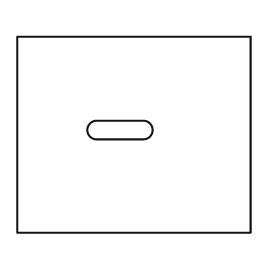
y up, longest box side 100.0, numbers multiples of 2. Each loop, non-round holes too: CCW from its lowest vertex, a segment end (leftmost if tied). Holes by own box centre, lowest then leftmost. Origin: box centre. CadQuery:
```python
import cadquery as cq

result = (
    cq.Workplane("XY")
    .moveTo(-50.0, -42.0)
    .lineTo(50.0, -42.0)
    .lineTo(50.0, 42.0)
    .lineTo(-50.0, 42.0)
    .close()
    .moveTo(-16.0, -2.0)
    .lineTo(4.0, -2.0)
    .threePointArc((8.0, 2.0), (4.0, 6.0))
    .lineTo(-16.0, 6.0)
    .threePointArc((-20.0, 2.0), (-16.0, -2.0))
    .close()
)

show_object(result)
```